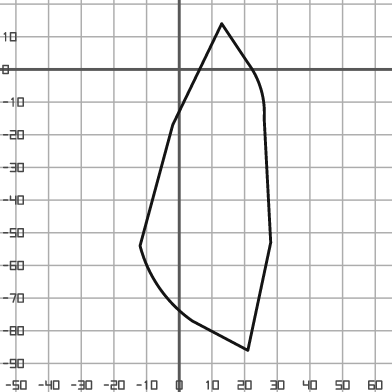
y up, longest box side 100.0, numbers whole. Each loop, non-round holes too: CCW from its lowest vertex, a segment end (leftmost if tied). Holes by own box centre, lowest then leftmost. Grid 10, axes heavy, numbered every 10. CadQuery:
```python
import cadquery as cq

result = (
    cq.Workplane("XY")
    .moveTo(21.0, -86.0)
    .lineTo(28.0, -53.0)
    .lineTo(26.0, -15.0)
    .threePointArc((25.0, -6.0), (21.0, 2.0))
    .lineTo(13.0, 14.0)
    .lineTo(-2.0, -17.0)
    .lineTo(-12.0, -54.0)
    .threePointArc((-6.0, -67.0), (4.0, -77.0))
    .close()
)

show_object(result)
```